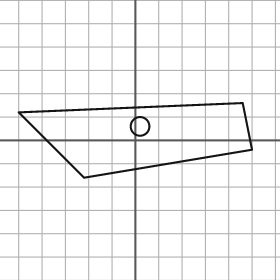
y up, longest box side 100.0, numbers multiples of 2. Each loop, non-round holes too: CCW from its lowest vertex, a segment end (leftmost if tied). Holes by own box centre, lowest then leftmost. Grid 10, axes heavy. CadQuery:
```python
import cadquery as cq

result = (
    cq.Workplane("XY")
    .moveTo(-22.0, -16.0)
    .lineTo(50.0, -4.0)
    .lineTo(46.0, 16.0)
    .lineTo(-50.0, 12.0)
    .close()
    .moveTo(2.0, 6.0)
    .circle(4.0)
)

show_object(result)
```